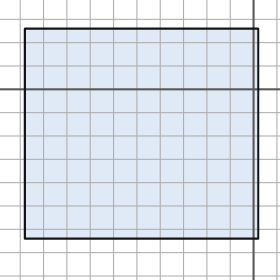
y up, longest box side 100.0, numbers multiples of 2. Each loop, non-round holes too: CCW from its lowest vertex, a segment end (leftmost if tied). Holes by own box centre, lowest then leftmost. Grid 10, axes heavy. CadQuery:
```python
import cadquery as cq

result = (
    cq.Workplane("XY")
    .moveTo(-98.0, -64.0)
    .lineTo(2.0, -64.0)
    .lineTo(2.0, 26.0)
    .lineTo(-98.0, 26.0)
    .close()
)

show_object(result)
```